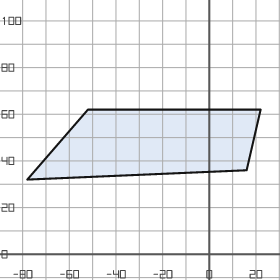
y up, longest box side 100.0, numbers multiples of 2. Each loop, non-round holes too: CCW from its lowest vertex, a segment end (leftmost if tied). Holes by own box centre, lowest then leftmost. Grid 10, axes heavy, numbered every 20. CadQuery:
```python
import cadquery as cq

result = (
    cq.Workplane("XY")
    .moveTo(-78.0, 32.0)
    .lineTo(16.0, 36.0)
    .lineTo(22.0, 62.0)
    .lineTo(-52.0, 62.0)
    .close()
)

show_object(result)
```